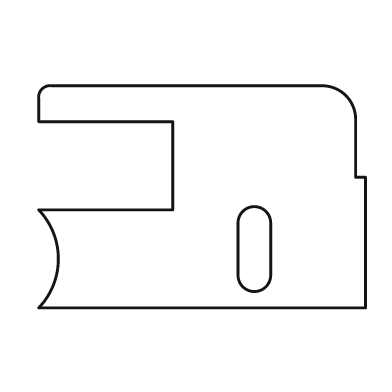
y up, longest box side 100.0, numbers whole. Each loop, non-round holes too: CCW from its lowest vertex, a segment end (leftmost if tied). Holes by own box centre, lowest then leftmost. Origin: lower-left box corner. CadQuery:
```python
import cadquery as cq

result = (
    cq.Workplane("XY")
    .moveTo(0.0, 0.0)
    .lineTo(100.0, 0.0)
    .lineTo(100.0, 40.0)
    .lineTo(97.0, 40.0)
    .lineTo(97.0, 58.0)
    .threePointArc((94.0, 65.0), (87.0, 68.0))
    .lineTo(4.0, 68.0)
    .threePointArc((1.0, 67.0), (0.0, 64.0))
    .lineTo(0.0, 57.0)
    .lineTo(41.0, 57.0)
    .lineTo(41.0, 30.0)
    .lineTo(0.0, 30.0)
    .threePointArc((6.0, 15.0), (0.0, 0.0))
    .close()
    .moveTo(61.0, 10.0)
    .threePointArc((66.0, 5.0), (71.0, 10.0))
    .lineTo(71.0, 26.0)
    .threePointArc((66.0, 31.0), (61.0, 26.0))
    .close()
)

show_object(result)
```